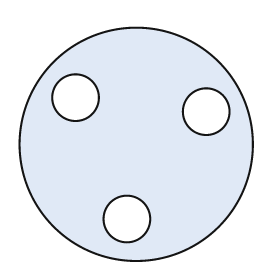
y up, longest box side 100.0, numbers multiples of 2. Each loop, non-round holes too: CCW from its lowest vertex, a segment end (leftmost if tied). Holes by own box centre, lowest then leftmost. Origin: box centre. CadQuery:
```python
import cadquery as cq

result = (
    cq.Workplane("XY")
    .moveTo(0.0, 0.0)
    .circle(50.0)
    .moveTo(-4.0, -32.0)
    .circle(10.0)
    .moveTo(30.0, 14.0)
    .circle(10.0)
    .moveTo(-26.0, 20.0)
    .circle(10.0)
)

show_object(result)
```